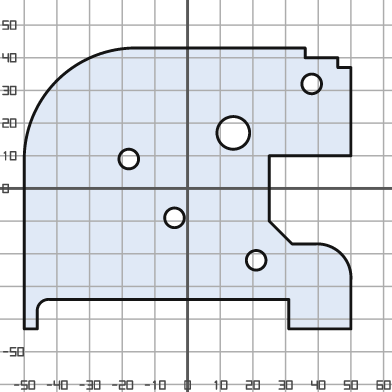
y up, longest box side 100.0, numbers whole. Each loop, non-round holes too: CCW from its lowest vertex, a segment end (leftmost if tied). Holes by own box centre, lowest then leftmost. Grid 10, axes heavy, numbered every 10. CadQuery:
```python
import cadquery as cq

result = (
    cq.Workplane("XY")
    .moveTo(-50.0, -43.0)
    .lineTo(-46.0, -43.0)
    .lineTo(-46.0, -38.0)
    .threePointArc((-45.0, -35.0), (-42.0, -34.0))
    .lineTo(31.0, -34.0)
    .lineTo(31.0, -43.0)
    .lineTo(50.0, -43.0)
    .lineTo(50.0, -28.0)
    .threePointArc((47.0, -20.0), (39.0, -17.0))
    .lineTo(32.0, -17.0)
    .lineTo(25.0, -10.0)
    .lineTo(25.0, 10.0)
    .lineTo(50.0, 10.0)
    .lineTo(50.0, 37.0)
    .lineTo(46.0, 37.0)
    .lineTo(46.0, 40.0)
    .lineTo(36.0, 40.0)
    .lineTo(36.0, 43.0)
    .lineTo(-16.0, 43.0)
    .threePointArc((-40.0, 33.0), (-50.0, 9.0))
    .close()
    .moveTo(21.0, -22.0)
    .circle(3.0)
    .moveTo(-4.0, -9.0)
    .circle(3.0)
    .moveTo(-18.0, 9.0)
    .circle(3.0)
    .moveTo(14.0, 17.0)
    .circle(5.0)
    .moveTo(38.0, 32.0)
    .circle(3.0)
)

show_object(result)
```